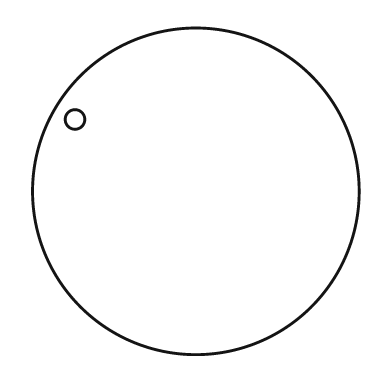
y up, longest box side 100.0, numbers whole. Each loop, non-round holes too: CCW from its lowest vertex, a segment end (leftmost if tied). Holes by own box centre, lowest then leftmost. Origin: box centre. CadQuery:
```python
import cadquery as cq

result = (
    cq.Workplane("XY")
    .moveTo(0.0, 0.0)
    .circle(50.0)
    .moveTo(-37.0, 22.0)
    .circle(3.0)
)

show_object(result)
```